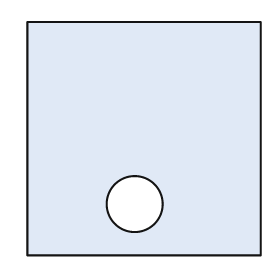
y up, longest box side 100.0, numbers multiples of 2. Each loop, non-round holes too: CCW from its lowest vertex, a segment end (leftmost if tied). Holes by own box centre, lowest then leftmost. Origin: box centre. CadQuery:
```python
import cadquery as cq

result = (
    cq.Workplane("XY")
    .moveTo(-50.0, -50.0)
    .lineTo(50.0, -50.0)
    .lineTo(50.0, 50.0)
    .lineTo(-50.0, 50.0)
    .close()
    .moveTo(-4.0, -28.0)
    .circle(12.0)
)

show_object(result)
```